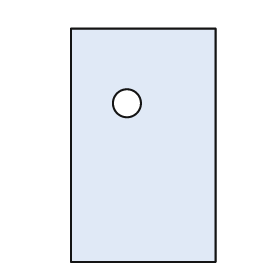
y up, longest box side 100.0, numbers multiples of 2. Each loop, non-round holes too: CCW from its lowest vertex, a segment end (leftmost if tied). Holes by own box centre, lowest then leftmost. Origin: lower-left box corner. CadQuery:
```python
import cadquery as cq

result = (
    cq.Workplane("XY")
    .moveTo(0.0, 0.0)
    .lineTo(62.0, 0.0)
    .lineTo(62.0, 100.0)
    .lineTo(0.0, 100.0)
    .close()
    .moveTo(24.0, 68.0)
    .circle(6.0)
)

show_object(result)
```